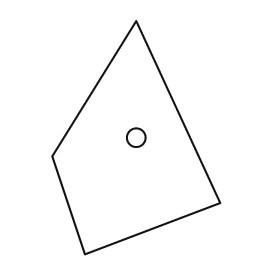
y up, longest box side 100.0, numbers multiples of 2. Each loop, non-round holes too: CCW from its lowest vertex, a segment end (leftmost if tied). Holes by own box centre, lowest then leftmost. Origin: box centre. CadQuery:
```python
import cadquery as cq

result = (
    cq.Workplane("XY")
    .moveTo(-22.0, -50.0)
    .lineTo(36.0, -28.0)
    .lineTo(0.0, 50.0)
    .lineTo(-36.0, -8.0)
    .close()
    .moveTo(0.0, 0.0)
    .circle(4.0)
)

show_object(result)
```